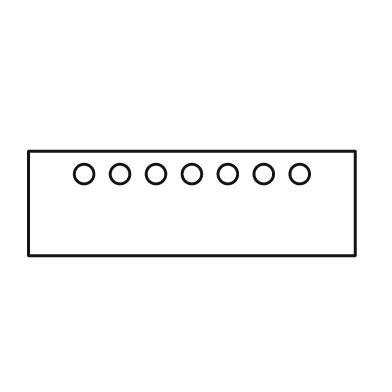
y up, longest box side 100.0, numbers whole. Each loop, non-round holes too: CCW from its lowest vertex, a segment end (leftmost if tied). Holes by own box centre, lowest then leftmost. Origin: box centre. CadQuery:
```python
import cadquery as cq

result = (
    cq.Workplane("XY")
    .moveTo(-50.0, -16.0)
    .lineTo(50.0, -16.0)
    .lineTo(50.0, 16.0)
    .lineTo(-50.0, 16.0)
    .close()
    .moveTo(-33.0, 9.0)
    .circle(3.0)
    .moveTo(-22.0, 9.0)
    .circle(3.0)
    .moveTo(-11.0, 9.0)
    .circle(3.0)
    .moveTo(0.0, 9.0)
    .circle(3.0)
    .moveTo(11.0, 9.0)
    .circle(3.0)
    .moveTo(22.0, 9.0)
    .circle(3.0)
    .moveTo(33.0, 9.0)
    .circle(3.0)
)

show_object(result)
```